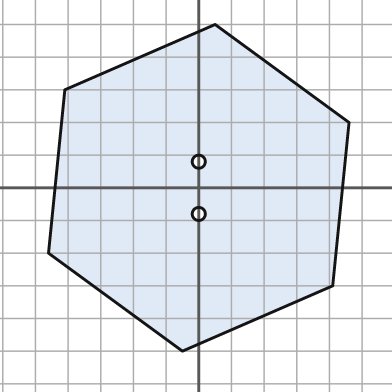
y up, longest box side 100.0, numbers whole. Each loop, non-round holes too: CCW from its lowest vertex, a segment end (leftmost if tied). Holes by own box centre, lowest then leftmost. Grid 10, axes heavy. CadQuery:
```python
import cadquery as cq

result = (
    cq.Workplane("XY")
    .moveTo(-5.0, -50.0)
    .lineTo(41.0, -30.0)
    .lineTo(46.0, 20.0)
    .lineTo(5.0, 50.0)
    .lineTo(-41.0, 30.0)
    .lineTo(-46.0, -20.0)
    .close()
    .moveTo(0.0, -8.0)
    .circle(2.0)
    .moveTo(0.0, 8.0)
    .circle(2.0)
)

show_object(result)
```